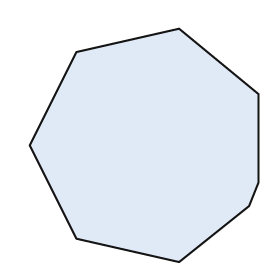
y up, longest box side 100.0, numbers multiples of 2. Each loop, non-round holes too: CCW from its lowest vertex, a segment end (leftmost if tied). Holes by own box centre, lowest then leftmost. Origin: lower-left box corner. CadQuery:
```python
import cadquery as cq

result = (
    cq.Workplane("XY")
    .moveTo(64.0, 0.0)
    .lineTo(94.0, 24.0)
    .lineTo(98.0, 34.0)
    .lineTo(98.0, 72.0)
    .lineTo(64.0, 100.0)
    .lineTo(20.0, 90.0)
    .lineTo(0.0, 50.0)
    .lineTo(20.0, 10.0)
    .close()
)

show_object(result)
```